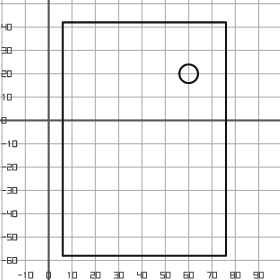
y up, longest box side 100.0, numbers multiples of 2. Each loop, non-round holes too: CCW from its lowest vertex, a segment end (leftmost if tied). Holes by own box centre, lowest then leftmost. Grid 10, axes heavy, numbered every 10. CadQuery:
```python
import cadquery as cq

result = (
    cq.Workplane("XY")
    .moveTo(6.0, -58.0)
    .lineTo(76.0, -58.0)
    .lineTo(76.0, 42.0)
    .lineTo(6.0, 42.0)
    .close()
    .moveTo(60.0, 20.0)
    .circle(4.0)
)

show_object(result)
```